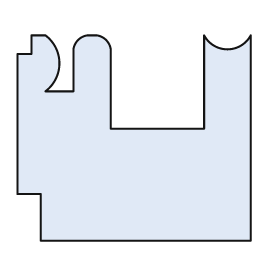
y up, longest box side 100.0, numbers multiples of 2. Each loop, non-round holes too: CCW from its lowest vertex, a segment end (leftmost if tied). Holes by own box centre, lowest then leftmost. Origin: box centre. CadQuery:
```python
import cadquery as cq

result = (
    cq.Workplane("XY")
    .moveTo(-40.0, -44.0)
    .lineTo(50.0, -44.0)
    .lineTo(50.0, 44.0)
    .threePointArc((40.0, 38.0), (30.0, 44.0))
    .lineTo(30.0, 4.0)
    .lineTo(-10.0, 4.0)
    .lineTo(-10.0, 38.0)
    .threePointArc((-12.0, 42.0), (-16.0, 44.0))
    .lineTo(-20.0, 44.0)
    .threePointArc((-24.0, 42.0), (-26.0, 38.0))
    .lineTo(-26.0, 20.0)
    .lineTo(-38.0, 20.0)
    .threePointArc((-32.0, 32.0), (-38.0, 44.0))
    .lineTo(-44.0, 44.0)
    .lineTo(-44.0, 36.0)
    .lineTo(-50.0, 36.0)
    .lineTo(-50.0, -24.0)
    .lineTo(-40.0, -24.0)
    .close()
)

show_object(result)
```